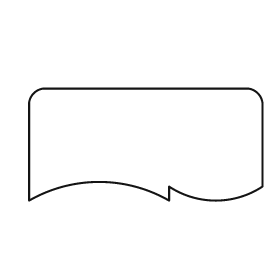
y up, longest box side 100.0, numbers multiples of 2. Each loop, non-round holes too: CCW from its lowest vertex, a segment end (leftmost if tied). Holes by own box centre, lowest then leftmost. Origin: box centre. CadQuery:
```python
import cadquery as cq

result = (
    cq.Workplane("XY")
    .moveTo(-50.0, -24.0)
    .threePointArc((-20.0, -16.0), (10.0, -24.0))
    .lineTo(10.0, -18.0)
    .threePointArc((30.0, -24.0), (50.0, -18.0))
    .lineTo(50.0, 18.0)
    .threePointArc((48.0, 22.0), (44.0, 24.0))
    .lineTo(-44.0, 24.0)
    .threePointArc((-48.0, 22.0), (-50.0, 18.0))
    .close()
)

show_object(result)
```